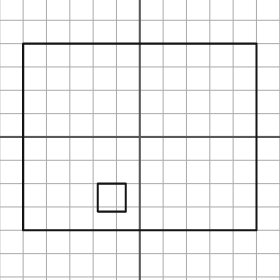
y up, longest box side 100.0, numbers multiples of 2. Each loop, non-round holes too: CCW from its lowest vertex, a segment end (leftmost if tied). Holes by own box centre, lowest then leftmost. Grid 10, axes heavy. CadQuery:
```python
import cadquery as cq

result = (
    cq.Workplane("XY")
    .moveTo(-50.0, -40.0)
    .lineTo(50.0, -40.0)
    .lineTo(50.0, 40.0)
    .lineTo(-50.0, 40.0)
    .close()
    .moveTo(-18.0, -32.0)
    .lineTo(-6.0, -32.0)
    .lineTo(-6.0, -20.0)
    .lineTo(-18.0, -20.0)
    .close()
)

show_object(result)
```